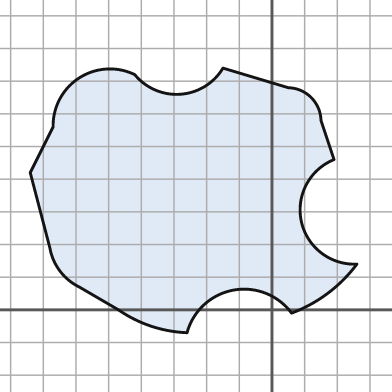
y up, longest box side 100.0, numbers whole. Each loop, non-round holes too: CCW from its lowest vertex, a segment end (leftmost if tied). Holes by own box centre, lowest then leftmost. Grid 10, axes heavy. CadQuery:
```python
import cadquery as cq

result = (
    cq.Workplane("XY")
    .moveTo(-26.0, -7.0)
    .threePointArc((-12.0, 6.0), (6.0, -1.0))
    .threePointArc((17.0, 5.0), (26.0, 14.0))
    .threePointArc((9.0, 27.0), (19.0, 46.0))
    .lineTo(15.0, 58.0)
    .threePointArc((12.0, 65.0), (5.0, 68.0))
    .lineTo(-15.0, 74.0)
    .threePointArc((-28.0, 66.0), (-42.0, 72.0))
    .threePointArc((-59.0, 71.0), (-67.0, 56.0))
    .lineTo(-74.0, 42.0)
    .lineTo(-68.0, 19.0)
    .threePointArc((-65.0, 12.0), (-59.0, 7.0))
    .lineTo(-47.0, 0.0)
    .threePointArc((-37.0, -5.0), (-26.0, -7.0))
    .close()
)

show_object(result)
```